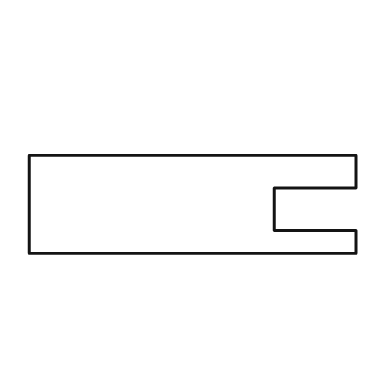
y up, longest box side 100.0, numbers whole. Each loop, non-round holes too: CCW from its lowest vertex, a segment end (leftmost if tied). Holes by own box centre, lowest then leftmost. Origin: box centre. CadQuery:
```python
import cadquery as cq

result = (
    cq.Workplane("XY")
    .moveTo(-50.0, -15.0)
    .lineTo(50.0, -15.0)
    .lineTo(50.0, -8.0)
    .lineTo(25.0, -8.0)
    .lineTo(25.0, 5.0)
    .lineTo(50.0, 5.0)
    .lineTo(50.0, 15.0)
    .lineTo(-50.0, 15.0)
    .close()
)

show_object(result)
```